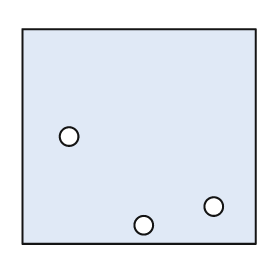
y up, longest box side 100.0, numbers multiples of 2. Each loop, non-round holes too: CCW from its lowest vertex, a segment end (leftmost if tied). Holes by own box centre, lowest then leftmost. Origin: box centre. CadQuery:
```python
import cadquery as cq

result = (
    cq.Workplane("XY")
    .moveTo(-50.0, -46.0)
    .lineTo(50.0, -46.0)
    .lineTo(50.0, 46.0)
    .lineTo(-50.0, 46.0)
    .close()
    .moveTo(2.0, -38.0)
    .circle(4.0)
    .moveTo(32.0, -30.0)
    .circle(4.0)
    .moveTo(-30.0, 0.0)
    .circle(4.0)
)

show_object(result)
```